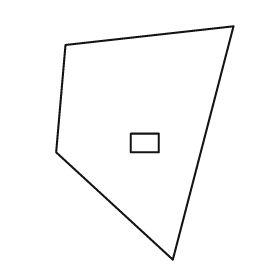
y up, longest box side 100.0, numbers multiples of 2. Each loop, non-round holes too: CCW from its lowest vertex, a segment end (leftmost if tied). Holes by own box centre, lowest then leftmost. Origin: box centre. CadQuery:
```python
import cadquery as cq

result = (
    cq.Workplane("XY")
    .moveTo(12.0, -50.0)
    .lineTo(38.0, 50.0)
    .lineTo(-34.0, 42.0)
    .lineTo(-38.0, -4.0)
    .close()
    .moveTo(-6.0, -4.0)
    .lineTo(6.0, -4.0)
    .lineTo(6.0, 4.0)
    .lineTo(-6.0, 4.0)
    .close()
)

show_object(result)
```